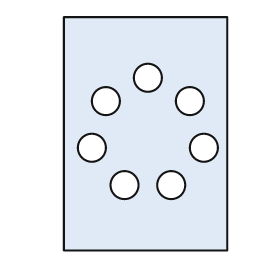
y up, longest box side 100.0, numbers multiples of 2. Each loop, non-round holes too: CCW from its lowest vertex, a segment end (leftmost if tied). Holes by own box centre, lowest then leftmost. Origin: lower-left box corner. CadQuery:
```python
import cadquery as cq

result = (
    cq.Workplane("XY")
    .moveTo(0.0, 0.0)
    .lineTo(70.0, 0.0)
    .lineTo(70.0, 100.0)
    .lineTo(0.0, 100.0)
    .close()
    .moveTo(26.0, 28.0)
    .circle(6.0)
    .moveTo(46.0, 28.0)
    .circle(6.0)
    .moveTo(12.0, 44.0)
    .circle(6.0)
    .moveTo(60.0, 44.0)
    .circle(6.0)
    .moveTo(18.0, 64.0)
    .circle(6.0)
    .moveTo(54.0, 64.0)
    .circle(6.0)
    .moveTo(36.0, 74.0)
    .circle(6.0)
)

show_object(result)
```